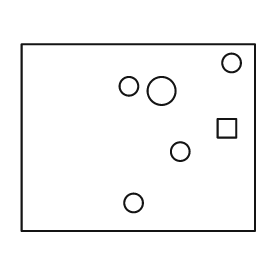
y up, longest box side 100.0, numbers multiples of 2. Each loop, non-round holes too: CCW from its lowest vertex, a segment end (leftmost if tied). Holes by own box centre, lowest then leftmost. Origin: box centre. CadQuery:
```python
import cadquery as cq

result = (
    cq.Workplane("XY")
    .moveTo(-50.0, -40.0)
    .lineTo(50.0, -40.0)
    .lineTo(50.0, 40.0)
    .lineTo(-50.0, 40.0)
    .close()
    .moveTo(-2.0, -28.0)
    .circle(4.0)
    .moveTo(18.0, -6.0)
    .circle(4.0)
    .moveTo(34.0, 0.0)
    .lineTo(42.0, 0.0)
    .lineTo(42.0, 8.0)
    .lineTo(34.0, 8.0)
    .close()
    .moveTo(10.0, 20.0)
    .circle(6.0)
    .moveTo(-4.0, 22.0)
    .circle(4.0)
    .moveTo(40.0, 32.0)
    .circle(4.0)
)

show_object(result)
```